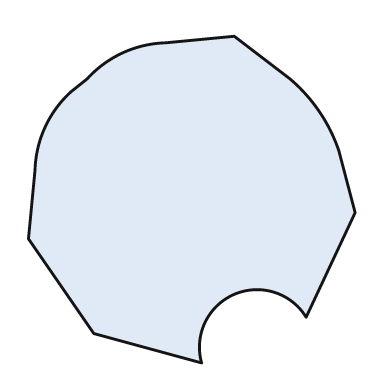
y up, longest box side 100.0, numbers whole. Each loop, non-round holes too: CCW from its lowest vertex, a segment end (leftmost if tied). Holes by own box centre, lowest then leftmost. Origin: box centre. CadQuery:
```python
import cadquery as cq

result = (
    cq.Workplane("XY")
    .moveTo(3.0, -50.0)
    .threePointArc((13.0, -29.0), (35.0, -36.0))
    .lineTo(50.0, -4.0)
    .lineTo(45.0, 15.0)
    .threePointArc((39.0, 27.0), (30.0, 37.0))
    .lineTo(13.0, 50.0)
    .lineTo(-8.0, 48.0)
    .threePointArc((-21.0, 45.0), (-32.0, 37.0))
    .lineTo(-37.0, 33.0)
    .threePointArc((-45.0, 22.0), (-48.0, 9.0))
    .lineTo(-50.0, -12.0)
    .lineTo(-30.0, -41.0)
    .close()
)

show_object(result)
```